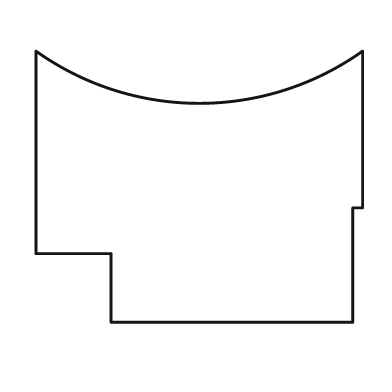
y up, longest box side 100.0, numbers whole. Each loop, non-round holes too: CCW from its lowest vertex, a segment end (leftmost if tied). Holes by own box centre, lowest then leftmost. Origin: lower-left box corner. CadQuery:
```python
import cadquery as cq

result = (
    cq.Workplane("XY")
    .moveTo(23.0, 0.0)
    .lineTo(97.0, 0.0)
    .lineTo(97.0, 35.0)
    .lineTo(100.0, 35.0)
    .lineTo(100.0, 83.0)
    .threePointArc((50.0, 67.0), (0.0, 83.0))
    .lineTo(0.0, 21.0)
    .lineTo(23.0, 21.0)
    .close()
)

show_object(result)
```